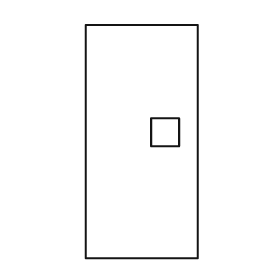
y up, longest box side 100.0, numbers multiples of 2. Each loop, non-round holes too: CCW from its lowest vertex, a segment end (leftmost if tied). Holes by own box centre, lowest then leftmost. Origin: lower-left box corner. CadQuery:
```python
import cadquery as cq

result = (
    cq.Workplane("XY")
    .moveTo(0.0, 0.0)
    .lineTo(48.0, 0.0)
    .lineTo(48.0, 100.0)
    .lineTo(0.0, 100.0)
    .close()
    .moveTo(28.0, 48.0)
    .lineTo(40.0, 48.0)
    .lineTo(40.0, 60.0)
    .lineTo(28.0, 60.0)
    .close()
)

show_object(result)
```